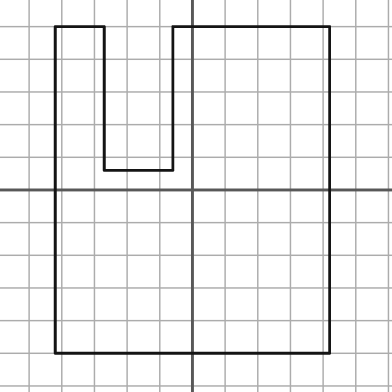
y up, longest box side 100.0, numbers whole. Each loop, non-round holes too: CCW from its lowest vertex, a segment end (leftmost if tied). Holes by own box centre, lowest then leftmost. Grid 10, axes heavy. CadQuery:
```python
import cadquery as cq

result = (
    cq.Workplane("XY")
    .moveTo(-42.0, -50.0)
    .lineTo(42.0, -50.0)
    .lineTo(42.0, 50.0)
    .lineTo(-6.0, 50.0)
    .lineTo(-6.0, 6.0)
    .lineTo(-27.0, 6.0)
    .lineTo(-27.0, 50.0)
    .lineTo(-42.0, 50.0)
    .close()
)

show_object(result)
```